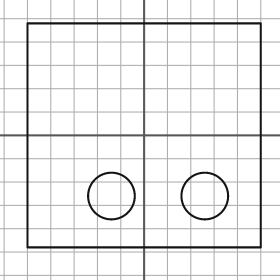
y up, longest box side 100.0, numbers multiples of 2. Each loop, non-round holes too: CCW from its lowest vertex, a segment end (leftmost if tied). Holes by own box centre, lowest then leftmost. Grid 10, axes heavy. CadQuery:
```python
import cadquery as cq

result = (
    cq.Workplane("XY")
    .moveTo(-50.0, -48.0)
    .lineTo(50.0, -48.0)
    .lineTo(50.0, 48.0)
    .lineTo(-50.0, 48.0)
    .close()
    .moveTo(-14.0, -26.0)
    .circle(10.0)
    .moveTo(26.0, -26.0)
    .circle(10.0)
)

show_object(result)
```